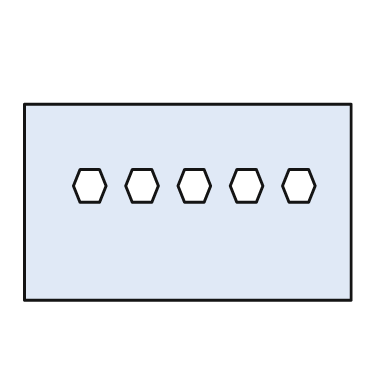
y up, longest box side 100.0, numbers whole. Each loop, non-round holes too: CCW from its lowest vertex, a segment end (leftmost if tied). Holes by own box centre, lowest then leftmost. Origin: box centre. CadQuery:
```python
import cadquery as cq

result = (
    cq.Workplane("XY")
    .moveTo(-50.0, -30.0)
    .lineTo(50.0, -30.0)
    .lineTo(50.0, 30.0)
    .lineTo(-50.0, 30.0)
    .close()
    .moveTo(-33.0, 0.0)
    .lineTo(-27.0, 0.0)
    .lineTo(-25.0, 5.0)
    .lineTo(-27.0, 10.0)
    .lineTo(-33.0, 10.0)
    .lineTo(-35.0, 5.0)
    .close()
    .moveTo(-17.0, 0.0)
    .lineTo(-11.0, 0.0)
    .lineTo(-9.0, 5.0)
    .lineTo(-11.0, 10.0)
    .lineTo(-17.0, 10.0)
    .lineTo(-19.0, 5.0)
    .close()
    .moveTo(-1.0, 0.0)
    .lineTo(5.0, 0.0)
    .lineTo(7.0, 5.0)
    .lineTo(5.0, 10.0)
    .lineTo(-1.0, 10.0)
    .lineTo(-3.0, 5.0)
    .close()
    .moveTo(15.0, 0.0)
    .lineTo(21.0, 0.0)
    .lineTo(23.0, 5.0)
    .lineTo(21.0, 10.0)
    .lineTo(15.0, 10.0)
    .lineTo(13.0, 5.0)
    .close()
    .moveTo(31.0, 0.0)
    .lineTo(37.0, 0.0)
    .lineTo(39.0, 5.0)
    .lineTo(37.0, 10.0)
    .lineTo(31.0, 10.0)
    .lineTo(29.0, 5.0)
    .close()
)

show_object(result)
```